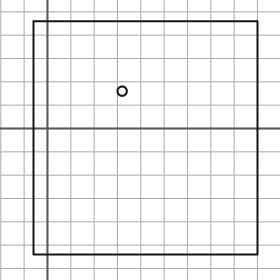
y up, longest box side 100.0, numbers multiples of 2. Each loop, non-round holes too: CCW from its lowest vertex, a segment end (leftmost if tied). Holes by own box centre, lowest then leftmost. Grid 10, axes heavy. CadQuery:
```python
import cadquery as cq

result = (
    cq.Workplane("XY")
    .moveTo(-6.0, -54.0)
    .lineTo(90.0, -54.0)
    .lineTo(90.0, 46.0)
    .lineTo(-6.0, 46.0)
    .close()
    .moveTo(32.0, 16.0)
    .circle(2.0)
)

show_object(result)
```